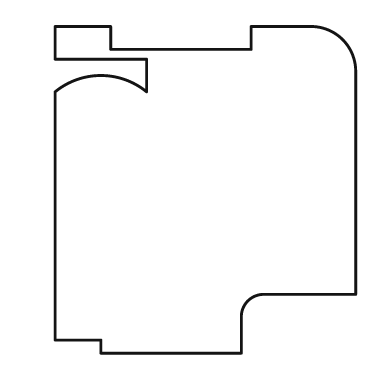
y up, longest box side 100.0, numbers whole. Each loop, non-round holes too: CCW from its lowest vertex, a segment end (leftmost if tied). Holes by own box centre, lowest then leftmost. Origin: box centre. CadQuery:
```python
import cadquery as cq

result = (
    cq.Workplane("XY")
    .moveTo(-32.0, -50.0)
    .lineTo(11.0, -50.0)
    .lineTo(11.0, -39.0)
    .threePointArc((13.0, -34.0), (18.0, -32.0))
    .lineTo(46.0, -32.0)
    .lineTo(46.0, 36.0)
    .threePointArc((42.0, 46.0), (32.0, 50.0))
    .lineTo(14.0, 50.0)
    .lineTo(14.0, 43.0)
    .lineTo(-29.0, 43.0)
    .lineTo(-29.0, 50.0)
    .lineTo(-46.0, 50.0)
    .lineTo(-46.0, 40.0)
    .lineTo(-18.0, 40.0)
    .lineTo(-18.0, 30.0)
    .threePointArc((-32.0, 35.0), (-46.0, 30.0))
    .lineTo(-46.0, -46.0)
    .lineTo(-32.0, -46.0)
    .close()
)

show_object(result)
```